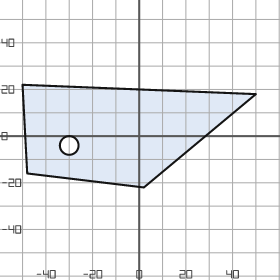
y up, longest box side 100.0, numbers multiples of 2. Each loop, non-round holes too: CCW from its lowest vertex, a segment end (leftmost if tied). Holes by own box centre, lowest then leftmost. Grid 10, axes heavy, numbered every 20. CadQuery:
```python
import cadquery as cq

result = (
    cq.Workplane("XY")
    .moveTo(2.0, -22.0)
    .lineTo(50.0, 18.0)
    .lineTo(-50.0, 22.0)
    .lineTo(-48.0, -16.0)
    .close()
    .moveTo(-30.0, -4.0)
    .circle(4.0)
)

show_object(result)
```